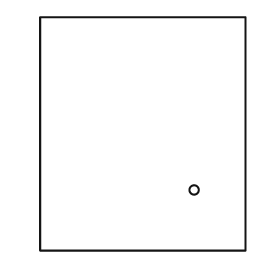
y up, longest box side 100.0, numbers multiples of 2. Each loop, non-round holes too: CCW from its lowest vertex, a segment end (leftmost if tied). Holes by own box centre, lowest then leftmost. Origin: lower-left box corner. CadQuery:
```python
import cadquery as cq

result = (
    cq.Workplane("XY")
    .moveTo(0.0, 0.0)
    .lineTo(88.0, 0.0)
    .lineTo(88.0, 100.0)
    .lineTo(0.0, 100.0)
    .close()
    .moveTo(66.0, 26.0)
    .circle(2.0)
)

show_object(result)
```